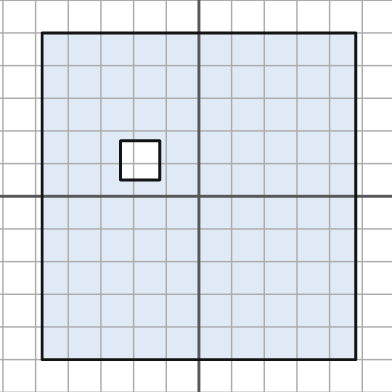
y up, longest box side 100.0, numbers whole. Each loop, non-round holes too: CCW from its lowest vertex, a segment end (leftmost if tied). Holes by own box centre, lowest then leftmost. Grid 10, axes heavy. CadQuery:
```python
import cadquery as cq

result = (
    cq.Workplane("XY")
    .moveTo(-48.0, -50.0)
    .lineTo(48.0, -50.0)
    .lineTo(48.0, 50.0)
    .lineTo(-48.0, 50.0)
    .close()
    .moveTo(-24.0, 5.0)
    .lineTo(-12.0, 5.0)
    .lineTo(-12.0, 17.0)
    .lineTo(-24.0, 17.0)
    .close()
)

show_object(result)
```